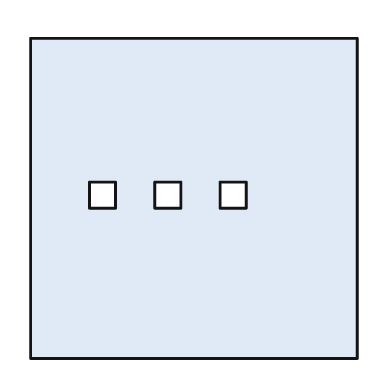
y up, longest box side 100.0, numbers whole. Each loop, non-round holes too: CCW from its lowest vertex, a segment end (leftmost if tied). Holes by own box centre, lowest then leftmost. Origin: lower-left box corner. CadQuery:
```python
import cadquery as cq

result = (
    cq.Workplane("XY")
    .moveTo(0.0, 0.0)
    .lineTo(100.0, 0.0)
    .lineTo(100.0, 98.0)
    .lineTo(0.0, 98.0)
    .close()
    .moveTo(18.0, 46.0)
    .lineTo(26.0, 46.0)
    .lineTo(26.0, 54.0)
    .lineTo(18.0, 54.0)
    .close()
    .moveTo(38.0, 46.0)
    .lineTo(46.0, 46.0)
    .lineTo(46.0, 54.0)
    .lineTo(38.0, 54.0)
    .close()
    .moveTo(58.0, 46.0)
    .lineTo(66.0, 46.0)
    .lineTo(66.0, 54.0)
    .lineTo(58.0, 54.0)
    .close()
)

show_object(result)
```